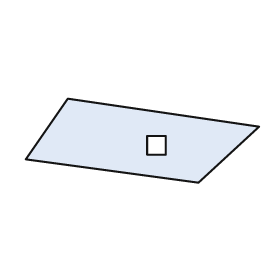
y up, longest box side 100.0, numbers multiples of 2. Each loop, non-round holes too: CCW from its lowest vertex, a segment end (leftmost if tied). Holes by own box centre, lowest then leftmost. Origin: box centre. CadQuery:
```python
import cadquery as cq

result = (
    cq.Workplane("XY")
    .moveTo(24.0, -18.0)
    .lineTo(50.0, 6.0)
    .lineTo(-32.0, 18.0)
    .lineTo(-50.0, -8.0)
    .close()
    .moveTo(2.0, -6.0)
    .lineTo(10.0, -6.0)
    .lineTo(10.0, 2.0)
    .lineTo(2.0, 2.0)
    .close()
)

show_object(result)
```